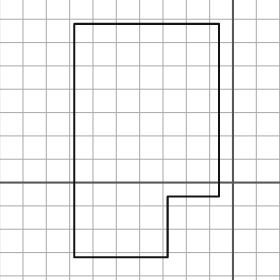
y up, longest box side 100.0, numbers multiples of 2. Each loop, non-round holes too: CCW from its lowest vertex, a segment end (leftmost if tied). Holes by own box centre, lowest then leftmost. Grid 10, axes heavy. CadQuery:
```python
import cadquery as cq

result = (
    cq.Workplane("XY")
    .moveTo(-68.0, -32.0)
    .lineTo(-28.0, -32.0)
    .lineTo(-28.0, -6.0)
    .lineTo(-6.0, -6.0)
    .lineTo(-6.0, 68.0)
    .lineTo(-68.0, 68.0)
    .close()
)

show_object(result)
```